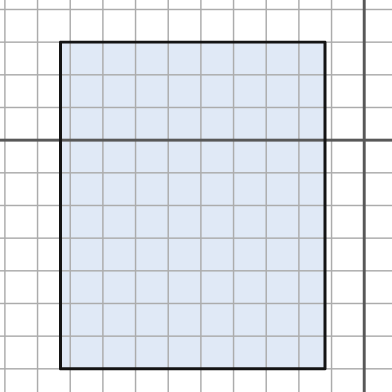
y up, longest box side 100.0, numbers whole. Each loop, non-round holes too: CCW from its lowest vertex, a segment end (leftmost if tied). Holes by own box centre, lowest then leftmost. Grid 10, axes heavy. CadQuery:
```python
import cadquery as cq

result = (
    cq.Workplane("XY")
    .moveTo(-93.0, -70.0)
    .lineTo(-12.0, -70.0)
    .lineTo(-12.0, 30.0)
    .lineTo(-93.0, 30.0)
    .close()
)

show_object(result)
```